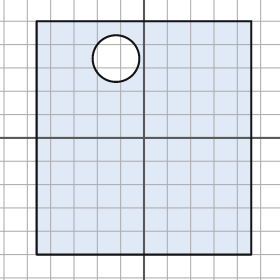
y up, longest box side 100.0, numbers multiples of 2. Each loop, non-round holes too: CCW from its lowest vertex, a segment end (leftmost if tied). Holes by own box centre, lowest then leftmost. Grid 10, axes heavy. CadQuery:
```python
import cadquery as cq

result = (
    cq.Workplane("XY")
    .moveTo(-46.0, -50.0)
    .lineTo(46.0, -50.0)
    .lineTo(46.0, 50.0)
    .lineTo(-46.0, 50.0)
    .close()
    .moveTo(-12.0, 34.0)
    .circle(10.0)
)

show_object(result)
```